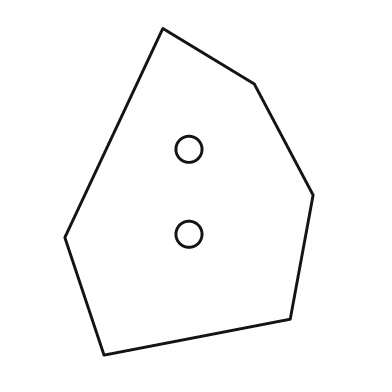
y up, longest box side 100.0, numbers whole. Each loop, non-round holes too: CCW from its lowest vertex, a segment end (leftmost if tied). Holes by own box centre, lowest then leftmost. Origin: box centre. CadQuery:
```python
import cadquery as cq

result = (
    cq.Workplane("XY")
    .moveTo(-26.0, -50.0)
    .lineTo(31.0, -39.0)
    .lineTo(38.0, -1.0)
    .lineTo(20.0, 33.0)
    .lineTo(-8.0, 50.0)
    .lineTo(-38.0, -14.0)
    .close()
    .moveTo(0.0, -13.0)
    .circle(4.0)
    .moveTo(0.0, 13.0)
    .circle(4.0)
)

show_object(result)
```